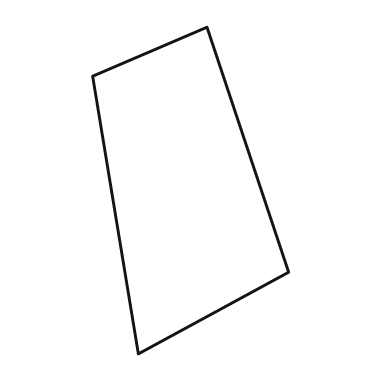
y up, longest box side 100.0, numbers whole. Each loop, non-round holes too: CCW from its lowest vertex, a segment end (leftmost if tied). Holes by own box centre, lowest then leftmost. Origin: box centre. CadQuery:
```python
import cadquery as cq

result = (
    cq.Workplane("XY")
    .moveTo(-16.0, -50.0)
    .lineTo(30.0, -25.0)
    .lineTo(5.0, 50.0)
    .lineTo(-30.0, 35.0)
    .close()
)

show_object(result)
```